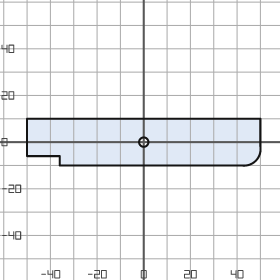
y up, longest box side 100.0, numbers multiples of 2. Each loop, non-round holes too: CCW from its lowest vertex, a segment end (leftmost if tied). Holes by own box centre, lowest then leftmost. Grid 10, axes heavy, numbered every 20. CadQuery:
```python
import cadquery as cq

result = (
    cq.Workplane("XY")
    .moveTo(-36.0, -10.0)
    .lineTo(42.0, -10.0)
    .threePointArc((48.0, -8.0), (50.0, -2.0))
    .lineTo(50.0, 10.0)
    .lineTo(-50.0, 10.0)
    .lineTo(-50.0, -6.0)
    .lineTo(-36.0, -6.0)
    .close()
    .moveTo(0.0, 0.0)
    .circle(2.0)
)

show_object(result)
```